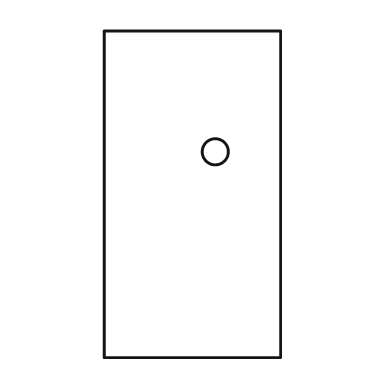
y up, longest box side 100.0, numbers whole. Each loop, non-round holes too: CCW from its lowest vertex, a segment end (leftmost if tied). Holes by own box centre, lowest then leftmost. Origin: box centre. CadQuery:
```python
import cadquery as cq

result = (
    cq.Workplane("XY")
    .moveTo(-27.0, -50.0)
    .lineTo(27.0, -50.0)
    .lineTo(27.0, 50.0)
    .lineTo(-27.0, 50.0)
    .close()
    .moveTo(7.0, 13.0)
    .circle(4.0)
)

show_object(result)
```